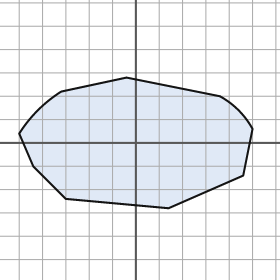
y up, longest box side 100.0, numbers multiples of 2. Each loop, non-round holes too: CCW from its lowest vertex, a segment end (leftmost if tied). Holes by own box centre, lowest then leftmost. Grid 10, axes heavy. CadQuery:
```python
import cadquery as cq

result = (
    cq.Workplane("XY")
    .moveTo(14.0, -28.0)
    .lineTo(46.0, -14.0)
    .lineTo(50.0, 6.0)
    .threePointArc((44.0, 14.0), (36.0, 20.0))
    .lineTo(-4.0, 28.0)
    .lineTo(-32.0, 22.0)
    .threePointArc((-42.0, 14.0), (-50.0, 4.0))
    .lineTo(-44.0, -10.0)
    .lineTo(-30.0, -24.0)
    .close()
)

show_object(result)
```